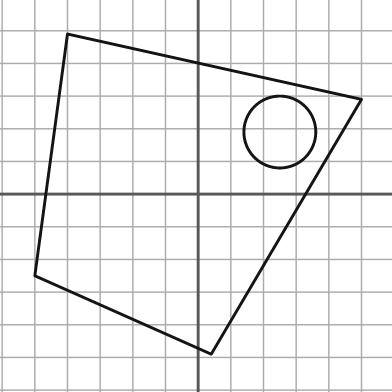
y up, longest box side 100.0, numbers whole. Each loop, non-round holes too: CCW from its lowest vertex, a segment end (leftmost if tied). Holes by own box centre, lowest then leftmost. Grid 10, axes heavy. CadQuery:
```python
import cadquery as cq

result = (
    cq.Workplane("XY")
    .moveTo(4.0, -49.0)
    .lineTo(50.0, 29.0)
    .lineTo(-40.0, 49.0)
    .lineTo(-50.0, -25.0)
    .close()
    .moveTo(25.0, 19.0)
    .circle(11.0)
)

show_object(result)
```